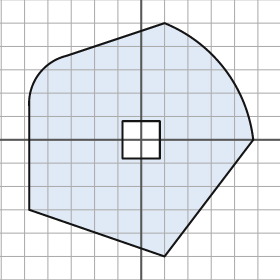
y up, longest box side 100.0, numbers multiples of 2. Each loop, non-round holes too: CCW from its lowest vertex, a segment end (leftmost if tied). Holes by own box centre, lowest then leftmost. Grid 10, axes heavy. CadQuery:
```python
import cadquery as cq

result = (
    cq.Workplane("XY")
    .moveTo(10.0, -50.0)
    .lineTo(48.0, 0.0)
    .threePointArc((36.0, 30.0), (10.0, 50.0))
    .lineTo(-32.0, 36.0)
    .threePointArc((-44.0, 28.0), (-48.0, 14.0))
    .lineTo(-48.0, -30.0)
    .close()
    .moveTo(-8.0, -8.0)
    .lineTo(8.0, -8.0)
    .lineTo(8.0, 8.0)
    .lineTo(-8.0, 8.0)
    .close()
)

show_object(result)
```